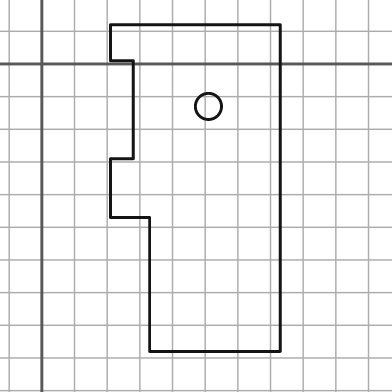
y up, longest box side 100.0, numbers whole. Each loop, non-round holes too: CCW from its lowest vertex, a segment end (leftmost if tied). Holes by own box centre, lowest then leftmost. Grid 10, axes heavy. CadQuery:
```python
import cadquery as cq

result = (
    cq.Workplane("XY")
    .moveTo(33.0, -88.0)
    .lineTo(73.0, -88.0)
    .lineTo(73.0, 12.0)
    .lineTo(21.0, 12.0)
    .lineTo(21.0, 1.0)
    .lineTo(28.0, 1.0)
    .lineTo(28.0, -29.0)
    .lineTo(21.0, -29.0)
    .lineTo(21.0, -47.0)
    .lineTo(33.0, -47.0)
    .close()
    .moveTo(51.0, -13.0)
    .circle(4.0)
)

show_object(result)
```